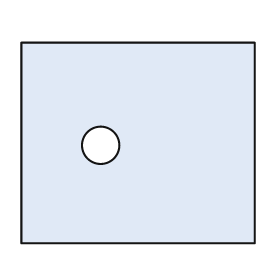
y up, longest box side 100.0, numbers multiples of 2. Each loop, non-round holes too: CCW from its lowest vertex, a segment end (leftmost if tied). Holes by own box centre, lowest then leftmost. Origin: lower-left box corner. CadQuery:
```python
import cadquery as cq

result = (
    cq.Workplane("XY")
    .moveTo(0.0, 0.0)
    .lineTo(100.0, 0.0)
    .lineTo(100.0, 86.0)
    .lineTo(0.0, 86.0)
    .close()
    .moveTo(34.0, 42.0)
    .circle(8.0)
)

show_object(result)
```